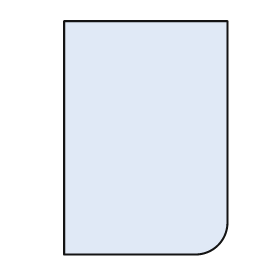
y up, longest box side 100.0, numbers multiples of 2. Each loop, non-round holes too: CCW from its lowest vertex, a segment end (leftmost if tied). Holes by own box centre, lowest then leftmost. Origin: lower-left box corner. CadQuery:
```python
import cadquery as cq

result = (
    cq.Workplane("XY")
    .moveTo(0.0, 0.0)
    .lineTo(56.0, 0.0)
    .threePointArc((66.0, 4.0), (70.0, 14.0))
    .lineTo(70.0, 100.0)
    .lineTo(0.0, 100.0)
    .close()
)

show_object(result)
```